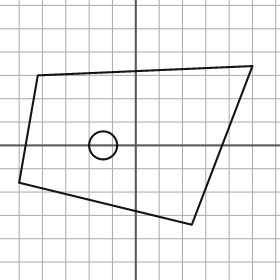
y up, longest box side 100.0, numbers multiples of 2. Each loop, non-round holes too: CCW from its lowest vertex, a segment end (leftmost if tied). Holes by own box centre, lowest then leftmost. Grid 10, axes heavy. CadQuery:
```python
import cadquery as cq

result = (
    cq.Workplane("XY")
    .moveTo(24.0, -34.0)
    .lineTo(50.0, 34.0)
    .lineTo(-42.0, 30.0)
    .lineTo(-50.0, -16.0)
    .close()
    .moveTo(-14.0, 0.0)
    .circle(6.0)
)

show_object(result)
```